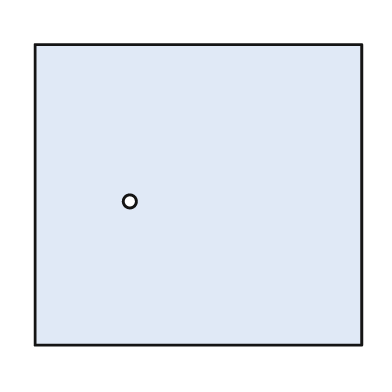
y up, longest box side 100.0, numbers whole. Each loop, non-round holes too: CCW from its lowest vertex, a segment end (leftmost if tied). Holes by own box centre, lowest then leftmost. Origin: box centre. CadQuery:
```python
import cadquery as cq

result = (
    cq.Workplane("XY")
    .moveTo(-50.0, -46.0)
    .lineTo(50.0, -46.0)
    .lineTo(50.0, 46.0)
    .lineTo(-50.0, 46.0)
    .close()
    .moveTo(-21.0, -2.0)
    .circle(2.0)
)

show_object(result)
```